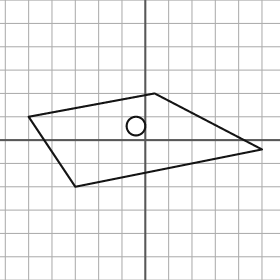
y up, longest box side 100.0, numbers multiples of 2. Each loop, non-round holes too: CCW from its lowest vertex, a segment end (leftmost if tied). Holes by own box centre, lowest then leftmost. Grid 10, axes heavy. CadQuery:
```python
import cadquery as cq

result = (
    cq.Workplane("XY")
    .moveTo(-30.0, -20.0)
    .lineTo(50.0, -4.0)
    .lineTo(4.0, 20.0)
    .lineTo(-50.0, 10.0)
    .close()
    .moveTo(-4.0, 6.0)
    .circle(4.0)
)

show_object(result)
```